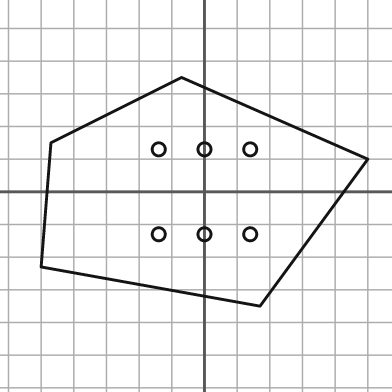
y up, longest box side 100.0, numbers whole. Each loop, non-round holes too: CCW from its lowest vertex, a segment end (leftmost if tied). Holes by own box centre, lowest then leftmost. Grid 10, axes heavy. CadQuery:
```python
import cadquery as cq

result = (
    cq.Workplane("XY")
    .moveTo(17.0, -35.0)
    .lineTo(50.0, 10.0)
    .lineTo(-7.0, 35.0)
    .lineTo(-47.0, 15.0)
    .lineTo(-50.0, -23.0)
    .close()
    .moveTo(-14.0, -13.0)
    .circle(2.0)
    .moveTo(0.0, -13.0)
    .circle(2.0)
    .moveTo(14.0, -13.0)
    .circle(2.0)
    .moveTo(-14.0, 13.0)
    .circle(2.0)
    .moveTo(0.0, 13.0)
    .circle(2.0)
    .moveTo(14.0, 13.0)
    .circle(2.0)
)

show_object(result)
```